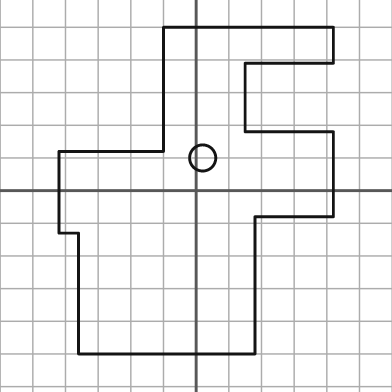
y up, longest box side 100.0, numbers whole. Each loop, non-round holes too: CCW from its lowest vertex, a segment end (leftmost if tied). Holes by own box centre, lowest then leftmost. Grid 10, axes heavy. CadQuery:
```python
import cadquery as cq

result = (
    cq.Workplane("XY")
    .moveTo(-36.0, -50.0)
    .lineTo(18.0, -50.0)
    .lineTo(18.0, -8.0)
    .lineTo(42.0, -8.0)
    .lineTo(42.0, 18.0)
    .lineTo(15.0, 18.0)
    .lineTo(15.0, 39.0)
    .lineTo(42.0, 39.0)
    .lineTo(42.0, 50.0)
    .lineTo(-10.0, 50.0)
    .lineTo(-10.0, 12.0)
    .lineTo(-42.0, 12.0)
    .lineTo(-42.0, -13.0)
    .lineTo(-36.0, -13.0)
    .close()
    .moveTo(2.0, 10.0)
    .circle(4.0)
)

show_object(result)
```